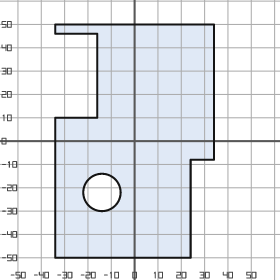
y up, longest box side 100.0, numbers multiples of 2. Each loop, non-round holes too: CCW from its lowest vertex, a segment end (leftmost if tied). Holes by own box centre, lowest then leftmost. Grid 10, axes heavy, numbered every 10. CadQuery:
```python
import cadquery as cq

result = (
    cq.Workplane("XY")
    .moveTo(-34.0, -50.0)
    .lineTo(24.0, -50.0)
    .lineTo(24.0, -8.0)
    .lineTo(34.0, -8.0)
    .lineTo(34.0, 50.0)
    .lineTo(-34.0, 50.0)
    .lineTo(-34.0, 46.0)
    .lineTo(-16.0, 46.0)
    .lineTo(-16.0, 10.0)
    .lineTo(-34.0, 10.0)
    .close()
    .moveTo(-14.0, -22.0)
    .circle(8.0)
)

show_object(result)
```